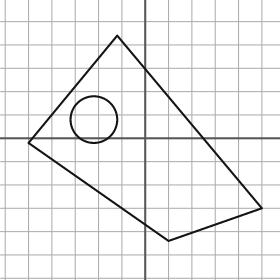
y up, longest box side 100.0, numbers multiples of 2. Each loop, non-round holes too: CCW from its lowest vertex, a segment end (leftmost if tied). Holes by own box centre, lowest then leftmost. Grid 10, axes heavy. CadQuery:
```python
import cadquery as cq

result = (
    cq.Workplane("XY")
    .moveTo(10.0, -44.0)
    .lineTo(50.0, -30.0)
    .lineTo(-12.0, 44.0)
    .lineTo(-50.0, -2.0)
    .close()
    .moveTo(-22.0, 8.0)
    .circle(10.0)
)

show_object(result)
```